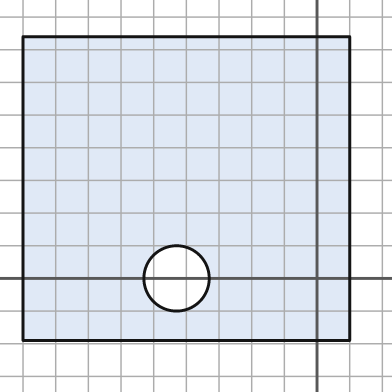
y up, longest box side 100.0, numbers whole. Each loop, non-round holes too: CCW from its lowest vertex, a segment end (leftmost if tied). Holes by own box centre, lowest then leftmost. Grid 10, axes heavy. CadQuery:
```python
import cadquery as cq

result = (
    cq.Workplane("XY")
    .moveTo(-90.0, -19.0)
    .lineTo(10.0, -19.0)
    .lineTo(10.0, 74.0)
    .lineTo(-90.0, 74.0)
    .close()
    .moveTo(-43.0, 0.0)
    .circle(10.0)
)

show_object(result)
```